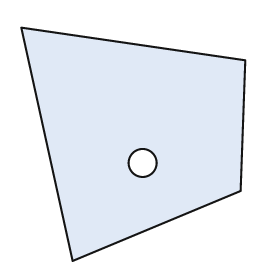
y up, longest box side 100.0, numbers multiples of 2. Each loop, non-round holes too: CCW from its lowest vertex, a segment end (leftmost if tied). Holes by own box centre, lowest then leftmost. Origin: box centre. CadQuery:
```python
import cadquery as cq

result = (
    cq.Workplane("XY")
    .moveTo(-26.0, -50.0)
    .lineTo(46.0, -20.0)
    .lineTo(48.0, 36.0)
    .lineTo(-48.0, 50.0)
    .close()
    .moveTo(4.0, -8.0)
    .circle(6.0)
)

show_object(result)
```